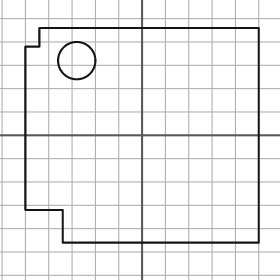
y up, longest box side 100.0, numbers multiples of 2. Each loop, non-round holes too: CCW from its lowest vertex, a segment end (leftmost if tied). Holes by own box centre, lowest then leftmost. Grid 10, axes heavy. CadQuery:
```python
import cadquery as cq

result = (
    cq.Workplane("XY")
    .moveTo(-34.0, -46.0)
    .lineTo(50.0, -46.0)
    .lineTo(50.0, 46.0)
    .lineTo(-44.0, 46.0)
    .lineTo(-44.0, 38.0)
    .lineTo(-50.0, 38.0)
    .lineTo(-50.0, -32.0)
    .lineTo(-34.0, -32.0)
    .close()
    .moveTo(-28.0, 32.0)
    .circle(8.0)
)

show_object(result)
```